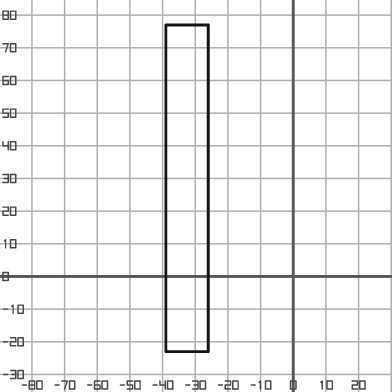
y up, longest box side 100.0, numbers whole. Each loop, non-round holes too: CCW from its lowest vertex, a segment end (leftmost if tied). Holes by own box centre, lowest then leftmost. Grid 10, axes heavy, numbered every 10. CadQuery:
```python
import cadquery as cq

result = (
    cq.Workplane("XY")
    .moveTo(-39.0, -23.0)
    .lineTo(-26.0, -23.0)
    .lineTo(-26.0, 77.0)
    .lineTo(-39.0, 77.0)
    .close()
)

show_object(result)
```